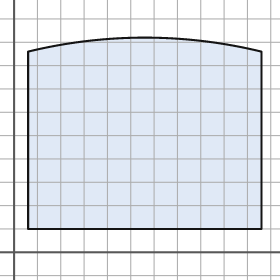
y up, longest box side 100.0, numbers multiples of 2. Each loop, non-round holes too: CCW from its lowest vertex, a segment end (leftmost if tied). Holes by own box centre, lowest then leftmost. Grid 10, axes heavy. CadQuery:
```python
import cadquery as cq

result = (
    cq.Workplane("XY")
    .moveTo(6.0, 10.0)
    .lineTo(106.0, 10.0)
    .lineTo(106.0, 86.0)
    .threePointArc((56.0, 92.0), (6.0, 86.0))
    .close()
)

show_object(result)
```